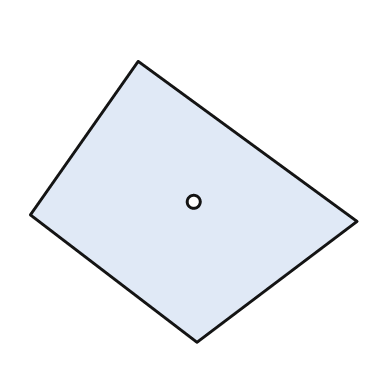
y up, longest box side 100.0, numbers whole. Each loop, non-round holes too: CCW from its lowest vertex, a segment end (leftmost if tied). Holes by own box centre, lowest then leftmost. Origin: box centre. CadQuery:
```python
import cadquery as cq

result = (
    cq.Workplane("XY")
    .moveTo(1.0, -43.0)
    .lineTo(50.0, -6.0)
    .lineTo(-17.0, 43.0)
    .lineTo(-50.0, -4.0)
    .close()
    .moveTo(0.0, 0.0)
    .circle(2.0)
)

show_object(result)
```